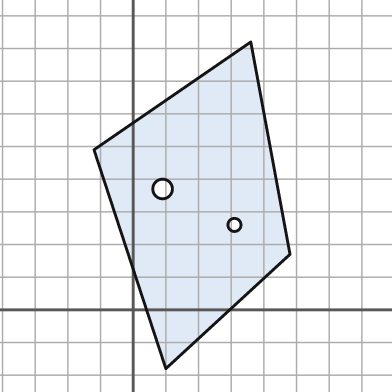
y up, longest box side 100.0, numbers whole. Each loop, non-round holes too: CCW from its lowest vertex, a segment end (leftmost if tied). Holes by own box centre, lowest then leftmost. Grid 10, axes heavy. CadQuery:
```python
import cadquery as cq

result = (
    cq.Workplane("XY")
    .moveTo(10.0, -18.0)
    .lineTo(48.0, 17.0)
    .lineTo(36.0, 82.0)
    .lineTo(-12.0, 49.0)
    .close()
    .moveTo(31.0, 26.0)
    .circle(2.0)
    .moveTo(9.0, 37.0)
    .circle(3.0)
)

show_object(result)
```